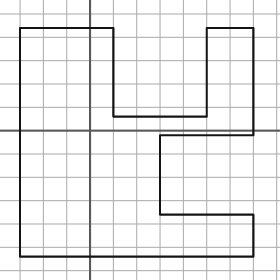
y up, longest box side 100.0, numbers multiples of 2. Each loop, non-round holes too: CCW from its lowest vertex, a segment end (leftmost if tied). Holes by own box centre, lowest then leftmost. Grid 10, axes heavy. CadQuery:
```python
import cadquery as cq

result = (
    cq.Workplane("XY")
    .moveTo(-30.0, -54.0)
    .lineTo(70.0, -54.0)
    .lineTo(70.0, -36.0)
    .lineTo(30.0, -36.0)
    .lineTo(30.0, -2.0)
    .lineTo(70.0, -2.0)
    .lineTo(70.0, 44.0)
    .lineTo(50.0, 44.0)
    .lineTo(50.0, 6.0)
    .lineTo(10.0, 6.0)
    .lineTo(10.0, 44.0)
    .lineTo(-30.0, 44.0)
    .close()
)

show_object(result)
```